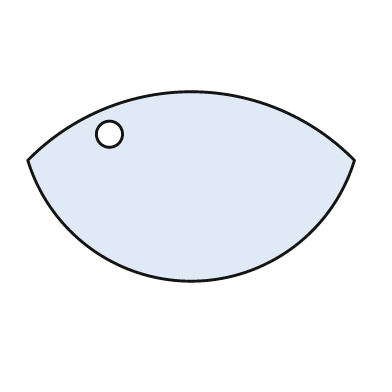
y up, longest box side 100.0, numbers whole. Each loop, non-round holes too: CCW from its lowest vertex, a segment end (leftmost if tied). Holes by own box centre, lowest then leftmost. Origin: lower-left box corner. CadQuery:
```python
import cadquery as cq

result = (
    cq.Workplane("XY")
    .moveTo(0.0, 37.0)
    .threePointArc((50.0, 0.0), (100.0, 37.0))
    .threePointArc((50.0, 58.0), (0.0, 37.0))
    .close()
    .moveTo(25.0, 45.0)
    .circle(4.0)
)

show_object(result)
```